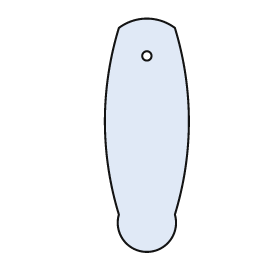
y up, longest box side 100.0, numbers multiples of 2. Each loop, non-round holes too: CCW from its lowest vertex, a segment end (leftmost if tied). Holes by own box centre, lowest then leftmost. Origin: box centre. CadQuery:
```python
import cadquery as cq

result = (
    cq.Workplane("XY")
    .moveTo(-12.0, -34.0)
    .threePointArc((0.0, -50.0), (12.0, -34.0))
    .threePointArc((18.0, 6.0), (12.0, 46.0))
    .threePointArc((0.0, 50.0), (-12.0, 46.0))
    .threePointArc((-18.0, 6.0), (-12.0, -34.0))
    .close()
    .moveTo(0.0, 34.0)
    .circle(2.0)
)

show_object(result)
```